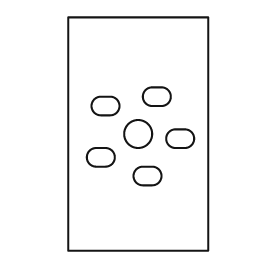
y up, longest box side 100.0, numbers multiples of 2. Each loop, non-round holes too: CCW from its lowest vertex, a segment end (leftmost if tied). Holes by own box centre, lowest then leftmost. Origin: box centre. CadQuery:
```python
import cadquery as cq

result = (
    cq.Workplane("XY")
    .moveTo(-30.0, -50.0)
    .lineTo(30.0, -50.0)
    .lineTo(30.0, 50.0)
    .lineTo(-30.0, 50.0)
    .close()
    .moveTo(2.0, -22.0)
    .lineTo(6.0, -22.0)
    .threePointArc((10.0, -18.0), (6.0, -14.0))
    .lineTo(2.0, -14.0)
    .threePointArc((-2.0, -18.0), (2.0, -22.0))
    .close()
    .moveTo(-18.0, -14.0)
    .lineTo(-14.0, -14.0)
    .threePointArc((-10.0, -10.0), (-14.0, -6.0))
    .lineTo(-18.0, -6.0)
    .threePointArc((-22.0, -10.0), (-18.0, -14.0))
    .close()
    .moveTo(16.0, -6.0)
    .lineTo(20.0, -6.0)
    .threePointArc((24.0, -2.0), (20.0, 2.0))
    .lineTo(16.0, 2.0)
    .threePointArc((12.0, -2.0), (16.0, -6.0))
    .close()
    .moveTo(0.0, 0.0)
    .circle(6.0)
    .moveTo(-16.0, 8.0)
    .lineTo(-12.0, 8.0)
    .threePointArc((-8.0, 12.0), (-12.0, 16.0))
    .lineTo(-16.0, 16.0)
    .threePointArc((-20.0, 12.0), (-16.0, 8.0))
    .close()
    .moveTo(6.0, 12.0)
    .lineTo(10.0, 12.0)
    .threePointArc((14.0, 16.0), (10.0, 20.0))
    .lineTo(6.0, 20.0)
    .threePointArc((2.0, 16.0), (6.0, 12.0))
    .close()
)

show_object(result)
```